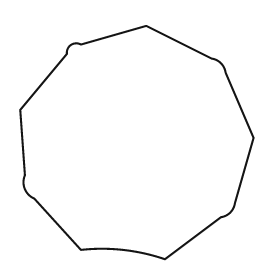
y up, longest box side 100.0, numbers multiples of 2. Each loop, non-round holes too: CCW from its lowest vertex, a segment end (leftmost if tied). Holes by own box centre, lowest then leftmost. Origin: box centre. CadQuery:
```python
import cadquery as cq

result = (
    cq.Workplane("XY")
    .moveTo(12.0, -50.0)
    .lineTo(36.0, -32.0)
    .threePointArc((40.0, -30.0), (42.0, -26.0))
    .lineTo(50.0, 2.0)
    .lineTo(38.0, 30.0)
    .threePointArc((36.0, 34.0), (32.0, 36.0))
    .lineTo(4.0, 50.0)
    .lineTo(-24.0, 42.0)
    .threePointArc((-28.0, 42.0), (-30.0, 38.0))
    .lineTo(-50.0, 14.0)
    .lineTo(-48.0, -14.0)
    .threePointArc((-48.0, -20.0), (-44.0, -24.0))
    .lineTo(-24.0, -46.0)
    .threePointArc((-6.0, -46.0), (12.0, -50.0))
    .close()
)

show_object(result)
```